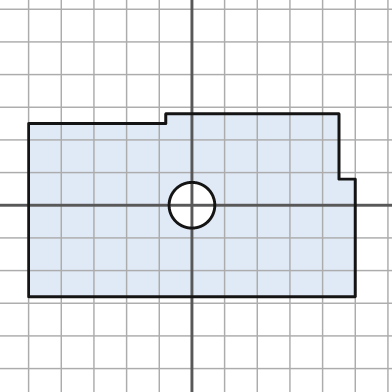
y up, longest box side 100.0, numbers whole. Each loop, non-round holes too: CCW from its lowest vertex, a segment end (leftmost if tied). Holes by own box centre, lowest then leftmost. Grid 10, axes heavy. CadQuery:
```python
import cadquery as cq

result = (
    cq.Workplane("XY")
    .moveTo(-50.0, -28.0)
    .lineTo(50.0, -28.0)
    .lineTo(50.0, 8.0)
    .lineTo(45.0, 8.0)
    .lineTo(45.0, 28.0)
    .lineTo(-8.0, 28.0)
    .lineTo(-8.0, 25.0)
    .lineTo(-50.0, 25.0)
    .close()
    .moveTo(0.0, 0.0)
    .circle(7.0)
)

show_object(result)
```